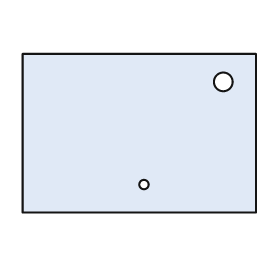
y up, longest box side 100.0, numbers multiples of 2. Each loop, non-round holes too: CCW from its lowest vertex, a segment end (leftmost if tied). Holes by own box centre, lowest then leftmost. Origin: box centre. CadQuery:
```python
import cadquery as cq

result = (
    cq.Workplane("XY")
    .moveTo(-50.0, -34.0)
    .lineTo(50.0, -34.0)
    .lineTo(50.0, 34.0)
    .lineTo(-50.0, 34.0)
    .close()
    .moveTo(2.0, -22.0)
    .circle(2.0)
    .moveTo(36.0, 22.0)
    .circle(4.0)
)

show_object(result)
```